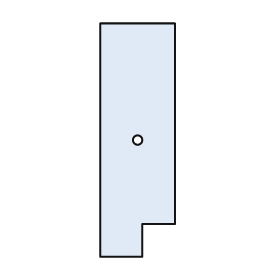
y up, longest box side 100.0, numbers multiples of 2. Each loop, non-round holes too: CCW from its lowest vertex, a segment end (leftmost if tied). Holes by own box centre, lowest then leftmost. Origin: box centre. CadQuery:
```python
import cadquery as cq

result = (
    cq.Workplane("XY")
    .moveTo(-16.0, -50.0)
    .lineTo(2.0, -50.0)
    .lineTo(2.0, -36.0)
    .lineTo(16.0, -36.0)
    .lineTo(16.0, 50.0)
    .lineTo(-16.0, 50.0)
    .close()
    .moveTo(0.0, 0.0)
    .circle(2.0)
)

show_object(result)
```